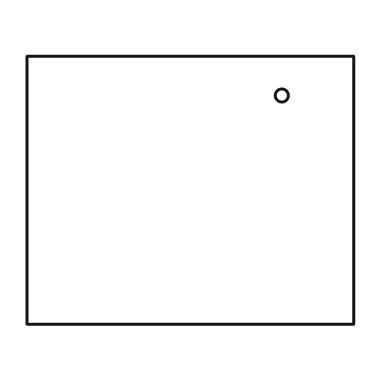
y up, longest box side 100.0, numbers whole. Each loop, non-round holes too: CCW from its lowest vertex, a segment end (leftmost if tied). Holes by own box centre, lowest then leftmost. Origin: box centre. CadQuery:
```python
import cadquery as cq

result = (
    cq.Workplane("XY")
    .moveTo(-50.0, -41.0)
    .lineTo(50.0, -41.0)
    .lineTo(50.0, 41.0)
    .lineTo(-50.0, 41.0)
    .close()
    .moveTo(28.0, 29.0)
    .circle(2.0)
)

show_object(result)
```